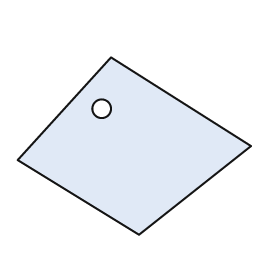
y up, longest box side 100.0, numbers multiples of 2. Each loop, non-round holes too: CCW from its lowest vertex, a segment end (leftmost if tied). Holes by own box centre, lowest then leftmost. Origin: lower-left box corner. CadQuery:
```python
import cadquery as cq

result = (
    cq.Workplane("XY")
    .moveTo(52.0, 0.0)
    .lineTo(100.0, 38.0)
    .lineTo(40.0, 76.0)
    .lineTo(0.0, 32.0)
    .close()
    .moveTo(36.0, 54.0)
    .circle(4.0)
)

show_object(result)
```